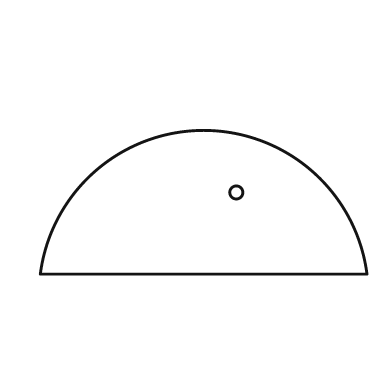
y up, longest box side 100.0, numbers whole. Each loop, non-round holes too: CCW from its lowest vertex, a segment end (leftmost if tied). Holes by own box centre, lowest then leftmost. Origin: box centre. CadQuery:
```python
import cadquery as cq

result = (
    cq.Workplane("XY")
    .moveTo(-50.0, -22.0)
    .lineTo(50.0, -22.0)
    .threePointArc((0.0, 22.0), (-50.0, -22.0))
    .close()
    .moveTo(10.0, 3.0)
    .circle(2.0)
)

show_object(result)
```